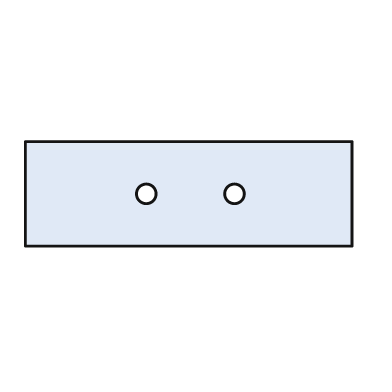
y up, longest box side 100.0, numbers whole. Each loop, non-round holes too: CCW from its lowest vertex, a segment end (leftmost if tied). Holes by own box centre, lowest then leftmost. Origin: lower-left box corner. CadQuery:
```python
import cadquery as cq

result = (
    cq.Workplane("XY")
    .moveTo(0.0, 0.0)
    .lineTo(100.0, 0.0)
    .lineTo(100.0, 32.0)
    .lineTo(0.0, 32.0)
    .close()
    .moveTo(37.0, 16.0)
    .circle(3.0)
    .moveTo(64.0, 16.0)
    .circle(3.0)
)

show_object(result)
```